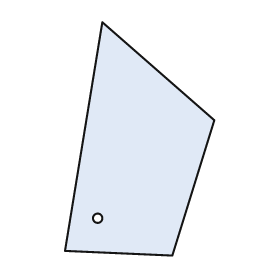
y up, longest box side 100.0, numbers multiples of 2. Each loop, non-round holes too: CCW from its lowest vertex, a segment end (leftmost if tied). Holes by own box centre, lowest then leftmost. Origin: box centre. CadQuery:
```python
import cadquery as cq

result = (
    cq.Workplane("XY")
    .moveTo(14.0, -50.0)
    .lineTo(32.0, 8.0)
    .lineTo(-16.0, 50.0)
    .lineTo(-32.0, -48.0)
    .close()
    .moveTo(-18.0, -34.0)
    .circle(2.0)
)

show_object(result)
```